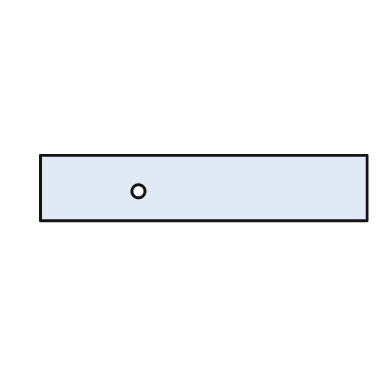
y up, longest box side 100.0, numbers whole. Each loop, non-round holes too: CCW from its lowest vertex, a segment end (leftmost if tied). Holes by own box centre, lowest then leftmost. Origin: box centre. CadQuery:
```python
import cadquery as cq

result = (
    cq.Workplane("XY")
    .moveTo(-50.0, -10.0)
    .lineTo(50.0, -10.0)
    .lineTo(50.0, 10.0)
    .lineTo(-50.0, 10.0)
    .close()
    .moveTo(-20.0, -1.0)
    .circle(2.0)
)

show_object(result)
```